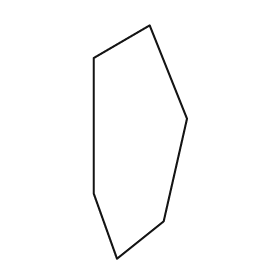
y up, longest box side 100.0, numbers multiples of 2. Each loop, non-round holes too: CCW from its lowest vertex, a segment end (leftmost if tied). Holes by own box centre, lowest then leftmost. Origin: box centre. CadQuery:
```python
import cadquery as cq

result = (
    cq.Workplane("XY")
    .moveTo(-10.0, -50.0)
    .lineTo(10.0, -34.0)
    .lineTo(20.0, 10.0)
    .lineTo(4.0, 50.0)
    .lineTo(-20.0, 36.0)
    .lineTo(-20.0, -22.0)
    .close()
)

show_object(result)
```